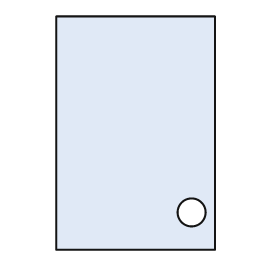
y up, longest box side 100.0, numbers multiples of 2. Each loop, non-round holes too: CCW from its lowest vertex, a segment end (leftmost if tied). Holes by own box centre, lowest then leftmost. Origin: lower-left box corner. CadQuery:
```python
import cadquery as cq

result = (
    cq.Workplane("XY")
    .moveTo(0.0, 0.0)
    .lineTo(68.0, 0.0)
    .lineTo(68.0, 100.0)
    .lineTo(0.0, 100.0)
    .close()
    .moveTo(58.0, 16.0)
    .circle(6.0)
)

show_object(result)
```